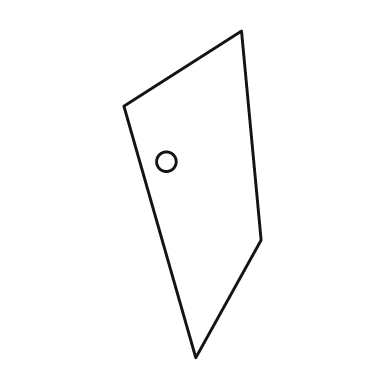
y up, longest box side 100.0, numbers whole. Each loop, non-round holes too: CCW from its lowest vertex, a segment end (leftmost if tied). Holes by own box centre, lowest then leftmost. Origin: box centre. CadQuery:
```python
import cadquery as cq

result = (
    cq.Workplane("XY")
    .moveTo(1.0, -50.0)
    .lineTo(21.0, -14.0)
    .lineTo(15.0, 50.0)
    .lineTo(-21.0, 27.0)
    .close()
    .moveTo(-8.0, 10.0)
    .circle(3.0)
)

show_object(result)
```